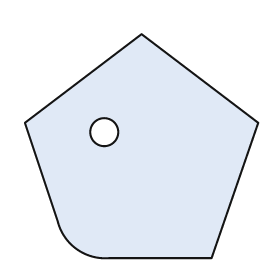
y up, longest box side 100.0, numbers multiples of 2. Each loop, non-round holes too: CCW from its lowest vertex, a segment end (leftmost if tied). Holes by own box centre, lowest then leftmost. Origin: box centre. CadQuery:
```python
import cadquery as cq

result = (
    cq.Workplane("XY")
    .moveTo(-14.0, -48.0)
    .lineTo(30.0, -48.0)
    .lineTo(50.0, 10.0)
    .lineTo(0.0, 48.0)
    .lineTo(-50.0, 10.0)
    .lineTo(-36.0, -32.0)
    .threePointArc((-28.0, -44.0), (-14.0, -48.0))
    .close()
    .moveTo(-16.0, 6.0)
    .circle(6.0)
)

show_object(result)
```